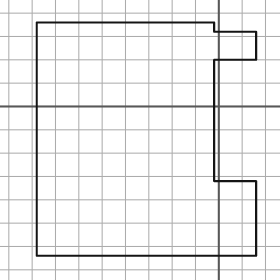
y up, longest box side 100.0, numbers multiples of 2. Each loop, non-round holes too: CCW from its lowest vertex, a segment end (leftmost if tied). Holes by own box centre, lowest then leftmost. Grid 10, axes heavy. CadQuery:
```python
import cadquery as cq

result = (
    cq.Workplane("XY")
    .moveTo(-78.0, -64.0)
    .lineTo(16.0, -64.0)
    .lineTo(16.0, -32.0)
    .lineTo(-2.0, -32.0)
    .lineTo(-2.0, 20.0)
    .lineTo(16.0, 20.0)
    .lineTo(16.0, 32.0)
    .lineTo(-2.0, 32.0)
    .lineTo(-2.0, 36.0)
    .lineTo(-78.0, 36.0)
    .close()
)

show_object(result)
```